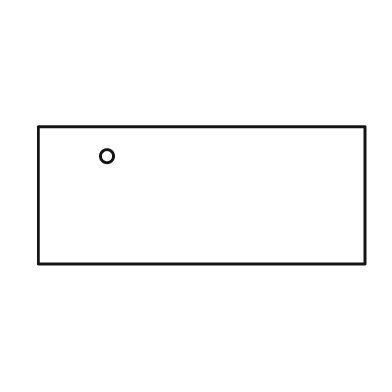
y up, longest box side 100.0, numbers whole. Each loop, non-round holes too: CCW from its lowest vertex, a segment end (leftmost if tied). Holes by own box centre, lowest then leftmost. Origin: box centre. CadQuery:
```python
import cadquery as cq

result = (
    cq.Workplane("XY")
    .moveTo(-50.0, -21.0)
    .lineTo(50.0, -21.0)
    .lineTo(50.0, 21.0)
    .lineTo(-50.0, 21.0)
    .close()
    .moveTo(-29.0, 12.0)
    .circle(2.0)
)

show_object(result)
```